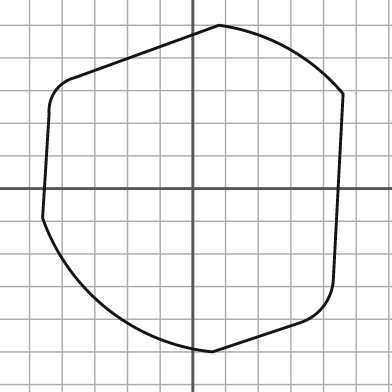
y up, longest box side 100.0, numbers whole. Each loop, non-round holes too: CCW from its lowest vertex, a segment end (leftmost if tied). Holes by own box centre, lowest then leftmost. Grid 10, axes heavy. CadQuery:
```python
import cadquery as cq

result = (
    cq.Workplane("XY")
    .moveTo(6.0, -50.0)
    .lineTo(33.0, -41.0)
    .threePointArc((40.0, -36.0), (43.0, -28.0))
    .lineTo(46.0, 29.0)
    .threePointArc((29.0, 43.0), (8.0, 50.0))
    .lineTo(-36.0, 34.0)
    .threePointArc((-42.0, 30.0), (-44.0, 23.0))
    .lineTo(-46.0, -9.0)
    .threePointArc((-26.0, -37.0), (6.0, -50.0))
    .close()
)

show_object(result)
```